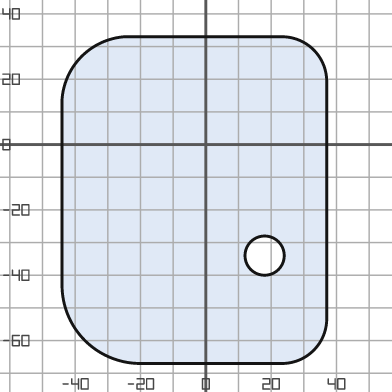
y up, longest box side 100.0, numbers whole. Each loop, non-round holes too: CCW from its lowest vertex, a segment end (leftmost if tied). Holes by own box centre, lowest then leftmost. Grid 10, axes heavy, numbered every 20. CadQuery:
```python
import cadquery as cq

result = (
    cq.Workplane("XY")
    .moveTo(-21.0, -67.0)
    .lineTo(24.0, -67.0)
    .threePointArc((33.0, -63.0), (37.0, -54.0))
    .lineTo(37.0, 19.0)
    .threePointArc((33.0, 29.0), (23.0, 33.0))
    .lineTo(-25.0, 33.0)
    .threePointArc((-38.0, 27.0), (-44.0, 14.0))
    .lineTo(-44.0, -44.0)
    .threePointArc((-37.0, -60.0), (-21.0, -67.0))
    .close()
    .moveTo(18.0, -34.0)
    .circle(6.0)
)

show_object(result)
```